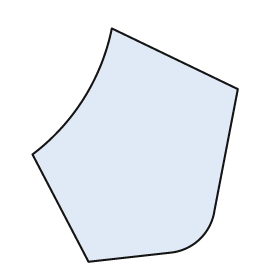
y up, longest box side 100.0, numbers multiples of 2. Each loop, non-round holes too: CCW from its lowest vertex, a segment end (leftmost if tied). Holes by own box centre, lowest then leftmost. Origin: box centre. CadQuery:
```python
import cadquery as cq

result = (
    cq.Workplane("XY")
    .moveTo(-20.0, -50.0)
    .lineTo(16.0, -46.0)
    .threePointArc((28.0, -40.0), (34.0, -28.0))
    .lineTo(44.0, 24.0)
    .lineTo(-10.0, 50.0)
    .threePointArc((-22.0, 20.0), (-44.0, -4.0))
    .close()
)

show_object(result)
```